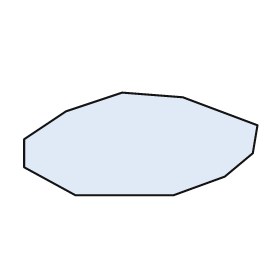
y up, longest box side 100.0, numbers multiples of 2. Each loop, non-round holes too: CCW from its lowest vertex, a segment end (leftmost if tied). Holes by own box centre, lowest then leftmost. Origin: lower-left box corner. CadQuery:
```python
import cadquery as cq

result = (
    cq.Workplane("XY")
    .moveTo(22.0, 0.0)
    .lineTo(64.0, 0.0)
    .lineTo(86.0, 8.0)
    .lineTo(98.0, 18.0)
    .lineTo(100.0, 30.0)
    .lineTo(68.0, 42.0)
    .lineTo(42.0, 44.0)
    .lineTo(18.0, 36.0)
    .lineTo(0.0, 24.0)
    .lineTo(0.0, 12.0)
    .close()
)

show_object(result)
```